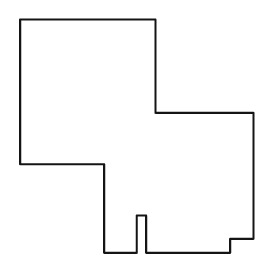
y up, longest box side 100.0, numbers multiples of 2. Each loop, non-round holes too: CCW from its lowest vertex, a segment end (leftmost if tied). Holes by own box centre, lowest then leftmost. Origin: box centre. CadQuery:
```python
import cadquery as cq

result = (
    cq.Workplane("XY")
    .moveTo(-14.0, -50.0)
    .lineTo(0.0, -50.0)
    .lineTo(0.0, -34.0)
    .lineTo(4.0, -34.0)
    .lineTo(4.0, -50.0)
    .lineTo(40.0, -50.0)
    .lineTo(40.0, -44.0)
    .lineTo(50.0, -44.0)
    .lineTo(50.0, 10.0)
    .lineTo(8.0, 10.0)
    .lineTo(8.0, 50.0)
    .lineTo(-50.0, 50.0)
    .lineTo(-50.0, -12.0)
    .lineTo(-14.0, -12.0)
    .close()
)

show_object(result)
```